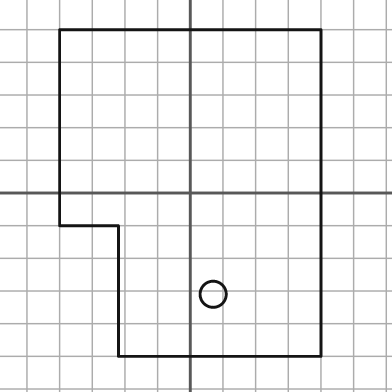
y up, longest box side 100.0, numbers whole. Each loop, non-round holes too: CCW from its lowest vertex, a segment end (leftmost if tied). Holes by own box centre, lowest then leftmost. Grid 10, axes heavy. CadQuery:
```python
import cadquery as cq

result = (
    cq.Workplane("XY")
    .moveTo(-22.0, -50.0)
    .lineTo(40.0, -50.0)
    .lineTo(40.0, 50.0)
    .lineTo(-40.0, 50.0)
    .lineTo(-40.0, -10.0)
    .lineTo(-22.0, -10.0)
    .close()
    .moveTo(7.0, -31.0)
    .circle(4.0)
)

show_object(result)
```